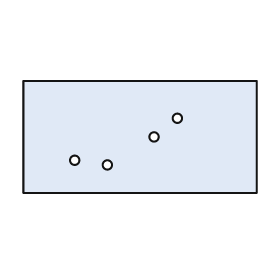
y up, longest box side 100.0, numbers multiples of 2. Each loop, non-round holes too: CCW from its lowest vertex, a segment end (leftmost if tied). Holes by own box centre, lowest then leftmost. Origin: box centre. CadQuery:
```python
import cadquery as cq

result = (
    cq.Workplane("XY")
    .moveTo(-50.0, -24.0)
    .lineTo(50.0, -24.0)
    .lineTo(50.0, 24.0)
    .lineTo(-50.0, 24.0)
    .close()
    .moveTo(-14.0, -12.0)
    .circle(2.0)
    .moveTo(-28.0, -10.0)
    .circle(2.0)
    .moveTo(6.0, 0.0)
    .circle(2.0)
    .moveTo(16.0, 8.0)
    .circle(2.0)
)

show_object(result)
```